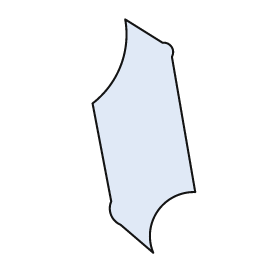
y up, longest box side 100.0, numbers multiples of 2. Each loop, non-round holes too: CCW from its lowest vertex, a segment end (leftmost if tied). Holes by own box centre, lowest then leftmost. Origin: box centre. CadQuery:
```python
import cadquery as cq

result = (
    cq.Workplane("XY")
    .moveTo(4.0, -50.0)
    .threePointArc((6.0, -32.0), (22.0, -24.0))
    .lineTo(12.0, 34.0)
    .threePointArc((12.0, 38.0), (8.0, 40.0))
    .lineTo(-8.0, 50.0)
    .threePointArc((-10.0, 30.0), (-22.0, 14.0))
    .lineTo(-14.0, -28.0)
    .threePointArc((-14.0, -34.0), (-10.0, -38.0))
    .close()
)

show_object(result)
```